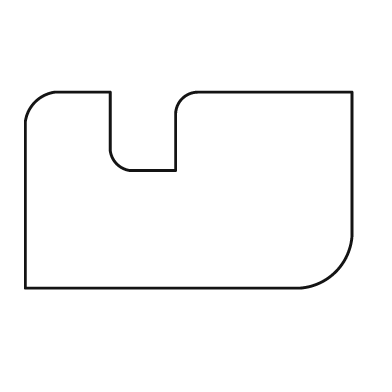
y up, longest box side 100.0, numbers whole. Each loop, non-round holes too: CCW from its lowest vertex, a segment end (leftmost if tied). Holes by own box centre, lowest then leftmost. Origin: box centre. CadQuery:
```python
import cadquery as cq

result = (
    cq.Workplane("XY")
    .moveTo(-50.0, -30.0)
    .lineTo(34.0, -30.0)
    .threePointArc((45.0, -25.0), (50.0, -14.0))
    .lineTo(50.0, 30.0)
    .lineTo(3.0, 30.0)
    .threePointArc((-2.0, 28.0), (-4.0, 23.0))
    .lineTo(-4.0, 6.0)
    .lineTo(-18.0, 6.0)
    .threePointArc((-22.0, 8.0), (-24.0, 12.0))
    .lineTo(-24.0, 30.0)
    .lineTo(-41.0, 30.0)
    .threePointArc((-47.0, 27.0), (-50.0, 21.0))
    .close()
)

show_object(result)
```